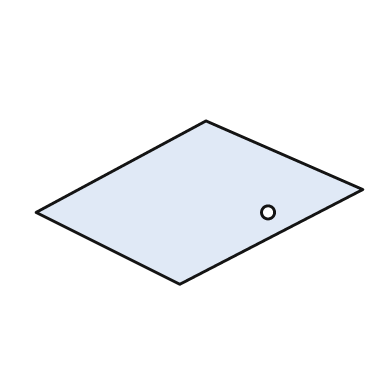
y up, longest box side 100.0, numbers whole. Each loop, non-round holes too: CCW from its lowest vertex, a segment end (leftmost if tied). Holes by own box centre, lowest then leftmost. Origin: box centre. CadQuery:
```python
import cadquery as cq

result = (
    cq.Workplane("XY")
    .moveTo(-6.0, -25.0)
    .lineTo(50.0, 4.0)
    .lineTo(2.0, 25.0)
    .lineTo(-50.0, -3.0)
    .close()
    .moveTo(21.0, -3.0)
    .circle(2.0)
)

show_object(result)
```